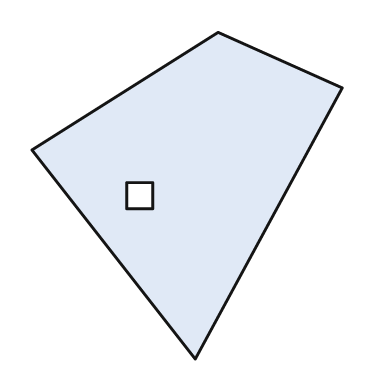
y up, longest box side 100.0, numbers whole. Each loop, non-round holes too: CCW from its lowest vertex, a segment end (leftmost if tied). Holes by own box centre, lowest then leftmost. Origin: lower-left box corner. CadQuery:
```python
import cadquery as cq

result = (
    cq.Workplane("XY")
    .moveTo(50.0, 0.0)
    .lineTo(95.0, 83.0)
    .lineTo(57.0, 100.0)
    .lineTo(0.0, 64.0)
    .close()
    .moveTo(29.0, 46.0)
    .lineTo(37.0, 46.0)
    .lineTo(37.0, 54.0)
    .lineTo(29.0, 54.0)
    .close()
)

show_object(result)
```